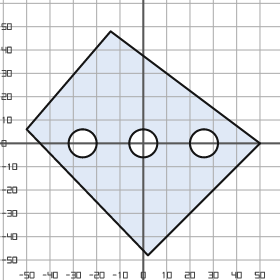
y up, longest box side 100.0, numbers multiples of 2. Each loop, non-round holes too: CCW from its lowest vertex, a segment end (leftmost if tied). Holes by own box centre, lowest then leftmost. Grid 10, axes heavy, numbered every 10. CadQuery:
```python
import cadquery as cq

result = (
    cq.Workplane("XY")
    .moveTo(2.0, -48.0)
    .lineTo(50.0, 0.0)
    .lineTo(-14.0, 48.0)
    .lineTo(-50.0, 6.0)
    .close()
    .moveTo(-26.0, 0.0)
    .circle(6.0)
    .moveTo(0.0, 0.0)
    .circle(6.0)
    .moveTo(26.0, 0.0)
    .circle(6.0)
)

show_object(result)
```